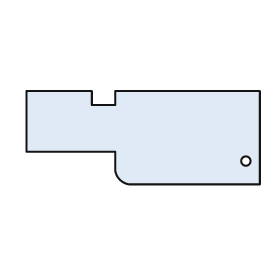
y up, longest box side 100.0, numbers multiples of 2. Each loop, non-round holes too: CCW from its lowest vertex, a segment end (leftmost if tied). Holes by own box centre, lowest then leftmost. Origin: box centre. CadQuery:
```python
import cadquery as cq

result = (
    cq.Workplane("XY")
    .moveTo(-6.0, -20.0)
    .lineTo(50.0, -20.0)
    .lineTo(50.0, 20.0)
    .lineTo(-12.0, 20.0)
    .lineTo(-12.0, 14.0)
    .lineTo(-22.0, 14.0)
    .lineTo(-22.0, 20.0)
    .lineTo(-50.0, 20.0)
    .lineTo(-50.0, -6.0)
    .lineTo(-12.0, -6.0)
    .lineTo(-12.0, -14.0)
    .threePointArc((-10.0, -18.0), (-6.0, -20.0))
    .close()
    .moveTo(44.0, -10.0)
    .circle(2.0)
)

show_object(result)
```